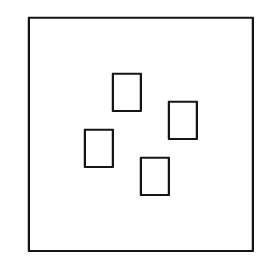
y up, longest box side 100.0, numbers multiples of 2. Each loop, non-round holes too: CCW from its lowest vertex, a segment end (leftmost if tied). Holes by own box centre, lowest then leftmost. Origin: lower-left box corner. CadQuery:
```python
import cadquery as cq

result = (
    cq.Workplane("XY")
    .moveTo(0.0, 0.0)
    .lineTo(96.0, 0.0)
    .lineTo(96.0, 100.0)
    .lineTo(0.0, 100.0)
    .close()
    .moveTo(48.0, 24.0)
    .lineTo(60.0, 24.0)
    .lineTo(60.0, 40.0)
    .lineTo(48.0, 40.0)
    .close()
    .moveTo(24.0, 36.0)
    .lineTo(36.0, 36.0)
    .lineTo(36.0, 52.0)
    .lineTo(24.0, 52.0)
    .close()
    .moveTo(60.0, 48.0)
    .lineTo(72.0, 48.0)
    .lineTo(72.0, 64.0)
    .lineTo(60.0, 64.0)
    .close()
    .moveTo(36.0, 60.0)
    .lineTo(48.0, 60.0)
    .lineTo(48.0, 76.0)
    .lineTo(36.0, 76.0)
    .close()
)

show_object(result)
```